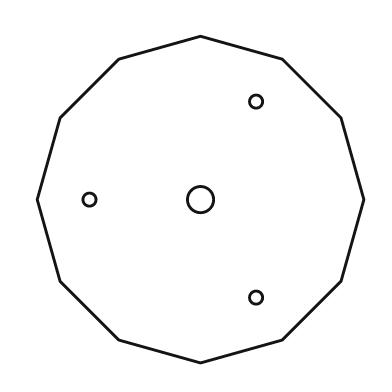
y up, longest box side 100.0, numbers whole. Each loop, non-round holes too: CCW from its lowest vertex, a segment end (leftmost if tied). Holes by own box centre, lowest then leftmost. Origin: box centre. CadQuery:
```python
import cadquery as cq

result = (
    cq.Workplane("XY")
    .moveTo(0.0, -50.0)
    .lineTo(25.0, -43.0)
    .lineTo(43.0, -25.0)
    .lineTo(50.0, 0.0)
    .lineTo(43.0, 25.0)
    .lineTo(25.0, 43.0)
    .lineTo(0.0, 50.0)
    .lineTo(-25.0, 43.0)
    .lineTo(-43.0, 25.0)
    .lineTo(-50.0, 0.0)
    .lineTo(-43.0, -25.0)
    .lineTo(-25.0, -43.0)
    .close()
    .moveTo(17.0, -30.0)
    .circle(2.0)
    .moveTo(-34.0, 0.0)
    .circle(2.0)
    .moveTo(0.0, 0.0)
    .circle(4.0)
    .moveTo(17.0, 30.0)
    .circle(2.0)
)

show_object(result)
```